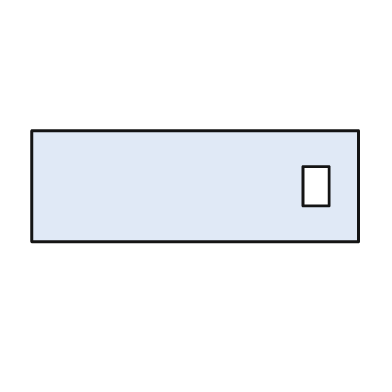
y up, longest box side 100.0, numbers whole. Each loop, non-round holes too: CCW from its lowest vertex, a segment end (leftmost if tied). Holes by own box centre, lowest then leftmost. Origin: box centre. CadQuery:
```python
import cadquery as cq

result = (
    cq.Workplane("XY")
    .moveTo(-50.0, -17.0)
    .lineTo(50.0, -17.0)
    .lineTo(50.0, 17.0)
    .lineTo(-50.0, 17.0)
    .close()
    .moveTo(33.0, -6.0)
    .lineTo(41.0, -6.0)
    .lineTo(41.0, 6.0)
    .lineTo(33.0, 6.0)
    .close()
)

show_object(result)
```